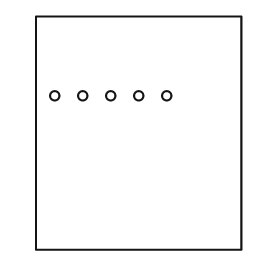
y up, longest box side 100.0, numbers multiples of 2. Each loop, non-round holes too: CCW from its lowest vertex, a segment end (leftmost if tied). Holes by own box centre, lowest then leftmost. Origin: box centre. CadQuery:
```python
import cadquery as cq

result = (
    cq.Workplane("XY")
    .moveTo(-44.0, -50.0)
    .lineTo(44.0, -50.0)
    .lineTo(44.0, 50.0)
    .lineTo(-44.0, 50.0)
    .close()
    .moveTo(-36.0, 16.0)
    .circle(2.0)
    .moveTo(-24.0, 16.0)
    .circle(2.0)
    .moveTo(-12.0, 16.0)
    .circle(2.0)
    .moveTo(0.0, 16.0)
    .circle(2.0)
    .moveTo(12.0, 16.0)
    .circle(2.0)
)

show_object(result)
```